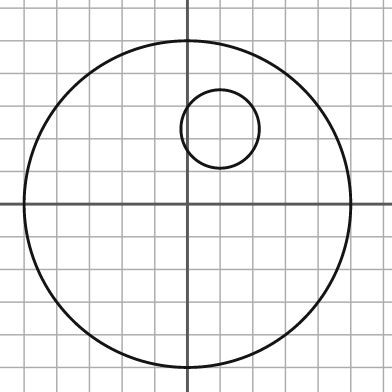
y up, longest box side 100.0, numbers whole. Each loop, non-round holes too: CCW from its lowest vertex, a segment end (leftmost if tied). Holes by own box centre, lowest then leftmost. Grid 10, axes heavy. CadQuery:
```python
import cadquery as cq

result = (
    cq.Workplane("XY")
    .moveTo(0.0, 0.0)
    .circle(50.0)
    .moveTo(10.0, 23.0)
    .circle(12.0)
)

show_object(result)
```